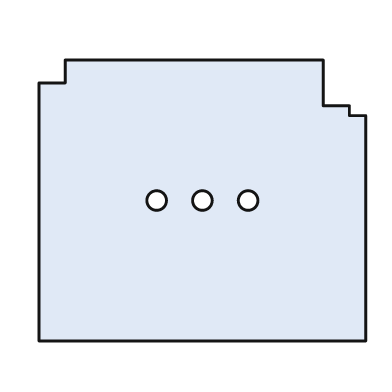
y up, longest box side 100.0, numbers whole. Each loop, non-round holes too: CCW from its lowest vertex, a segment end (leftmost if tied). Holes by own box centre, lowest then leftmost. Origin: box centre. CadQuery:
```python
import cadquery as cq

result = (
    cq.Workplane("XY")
    .moveTo(-50.0, -43.0)
    .lineTo(50.0, -43.0)
    .lineTo(50.0, 26.0)
    .lineTo(45.0, 26.0)
    .lineTo(45.0, 29.0)
    .lineTo(37.0, 29.0)
    .lineTo(37.0, 43.0)
    .lineTo(-42.0, 43.0)
    .lineTo(-42.0, 36.0)
    .lineTo(-50.0, 36.0)
    .close()
    .moveTo(-14.0, 0.0)
    .circle(3.0)
    .moveTo(0.0, 0.0)
    .circle(3.0)
    .moveTo(14.0, 0.0)
    .circle(3.0)
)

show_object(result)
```